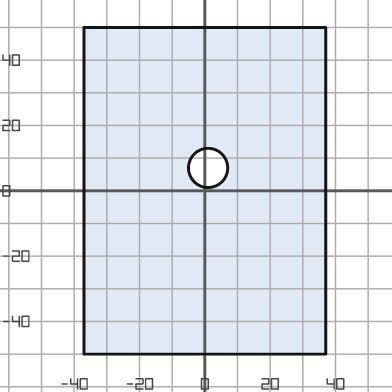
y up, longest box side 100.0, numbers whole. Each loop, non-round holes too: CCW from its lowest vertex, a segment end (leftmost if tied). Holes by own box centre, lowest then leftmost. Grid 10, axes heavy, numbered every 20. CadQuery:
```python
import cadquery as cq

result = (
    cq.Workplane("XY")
    .moveTo(-37.0, -50.0)
    .lineTo(37.0, -50.0)
    .lineTo(37.0, 50.0)
    .lineTo(-37.0, 50.0)
    .close()
    .moveTo(1.0, 7.0)
    .circle(6.0)
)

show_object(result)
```